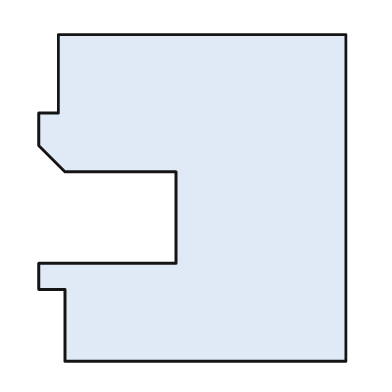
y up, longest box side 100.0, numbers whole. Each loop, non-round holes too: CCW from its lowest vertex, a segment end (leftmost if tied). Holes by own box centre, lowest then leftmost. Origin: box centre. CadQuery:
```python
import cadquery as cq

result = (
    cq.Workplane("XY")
    .moveTo(-39.0, -50.0)
    .lineTo(47.0, -50.0)
    .lineTo(47.0, 50.0)
    .lineTo(-41.0, 50.0)
    .lineTo(-41.0, 26.0)
    .lineTo(-47.0, 26.0)
    .lineTo(-47.0, 16.0)
    .lineTo(-39.0, 8.0)
    .lineTo(-5.0, 8.0)
    .lineTo(-5.0, -20.0)
    .lineTo(-47.0, -20.0)
    .lineTo(-47.0, -28.0)
    .lineTo(-39.0, -28.0)
    .close()
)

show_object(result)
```